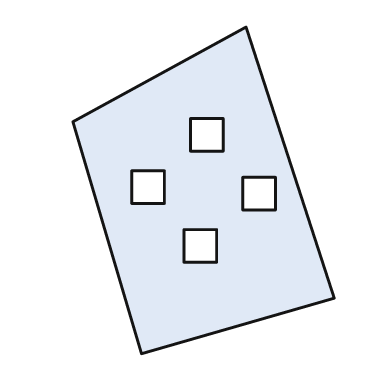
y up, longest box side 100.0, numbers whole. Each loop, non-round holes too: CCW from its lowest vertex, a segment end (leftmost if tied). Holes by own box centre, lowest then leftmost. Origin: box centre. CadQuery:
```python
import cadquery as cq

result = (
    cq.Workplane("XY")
    .moveTo(-19.0, -50.0)
    .lineTo(40.0, -33.0)
    .lineTo(13.0, 50.0)
    .lineTo(-40.0, 21.0)
    .close()
    .moveTo(-6.0, -22.0)
    .lineTo(4.0, -22.0)
    .lineTo(4.0, -12.0)
    .lineTo(-6.0, -12.0)
    .close()
    .moveTo(12.0, -6.0)
    .lineTo(22.0, -6.0)
    .lineTo(22.0, 4.0)
    .lineTo(12.0, 4.0)
    .close()
    .moveTo(-22.0, -4.0)
    .lineTo(-12.0, -4.0)
    .lineTo(-12.0, 6.0)
    .lineTo(-22.0, 6.0)
    .close()
    .moveTo(-4.0, 12.0)
    .lineTo(6.0, 12.0)
    .lineTo(6.0, 22.0)
    .lineTo(-4.0, 22.0)
    .close()
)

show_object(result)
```